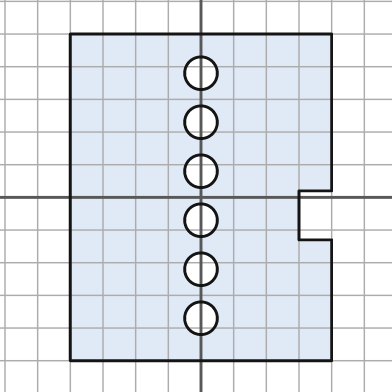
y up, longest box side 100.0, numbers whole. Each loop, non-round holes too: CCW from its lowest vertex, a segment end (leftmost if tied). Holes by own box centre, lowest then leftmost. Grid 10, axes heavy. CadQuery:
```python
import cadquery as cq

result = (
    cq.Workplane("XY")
    .moveTo(-40.0, -50.0)
    .lineTo(40.0, -50.0)
    .lineTo(40.0, -13.0)
    .lineTo(30.0, -13.0)
    .lineTo(30.0, 2.0)
    .lineTo(40.0, 2.0)
    .lineTo(40.0, 50.0)
    .lineTo(-40.0, 50.0)
    .close()
    .moveTo(0.0, -37.0)
    .circle(5.0)
    .moveTo(0.0, -22.0)
    .circle(5.0)
    .moveTo(0.0, -7.0)
    .circle(5.0)
    .moveTo(0.0, 8.0)
    .circle(5.0)
    .moveTo(0.0, 23.0)
    .circle(5.0)
    .moveTo(0.0, 38.0)
    .circle(5.0)
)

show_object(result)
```